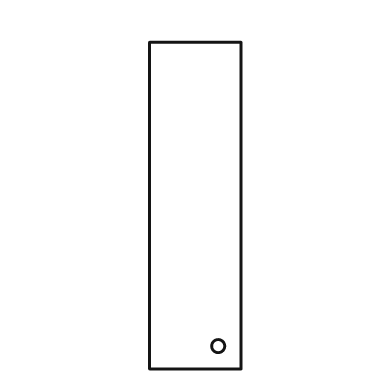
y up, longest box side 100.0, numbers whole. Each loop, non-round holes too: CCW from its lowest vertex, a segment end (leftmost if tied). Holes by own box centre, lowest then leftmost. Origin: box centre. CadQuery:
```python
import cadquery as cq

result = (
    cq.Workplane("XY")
    .moveTo(-14.0, -50.0)
    .lineTo(14.0, -50.0)
    .lineTo(14.0, 50.0)
    .lineTo(-14.0, 50.0)
    .close()
    .moveTo(7.0, -43.0)
    .circle(2.0)
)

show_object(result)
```